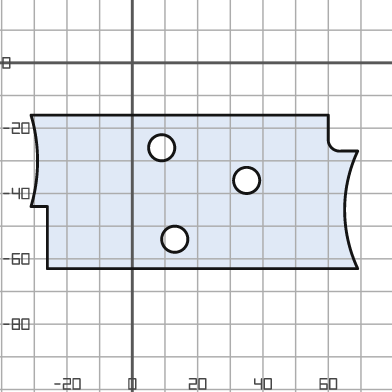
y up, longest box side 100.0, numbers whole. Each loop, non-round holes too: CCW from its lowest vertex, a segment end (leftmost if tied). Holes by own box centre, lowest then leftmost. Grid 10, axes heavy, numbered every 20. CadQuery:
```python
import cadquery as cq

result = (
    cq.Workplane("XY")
    .moveTo(-26.0, -63.0)
    .lineTo(69.0, -63.0)
    .threePointArc((65.0, -45.0), (69.0, -27.0))
    .lineTo(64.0, -27.0)
    .threePointArc((61.0, -26.0), (60.0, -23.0))
    .lineTo(60.0, -16.0)
    .lineTo(-31.0, -16.0)
    .threePointArc((-29.0, -30.0), (-31.0, -44.0))
    .lineTo(-26.0, -44.0)
    .close()
    .moveTo(13.0, -54.0)
    .circle(4.0)
    .moveTo(35.0, -36.0)
    .circle(4.0)
    .moveTo(9.0, -26.0)
    .circle(4.0)
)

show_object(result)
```